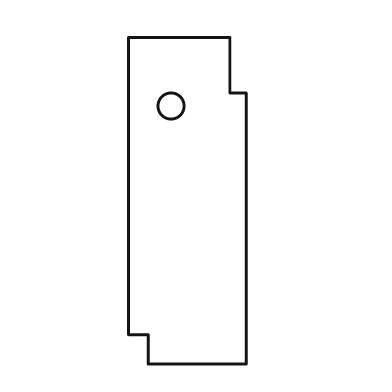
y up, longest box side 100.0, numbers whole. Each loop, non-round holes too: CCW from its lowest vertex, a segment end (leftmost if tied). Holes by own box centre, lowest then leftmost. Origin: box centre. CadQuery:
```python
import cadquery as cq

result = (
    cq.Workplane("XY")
    .moveTo(-12.0, -50.0)
    .lineTo(18.0, -50.0)
    .lineTo(18.0, 33.0)
    .lineTo(13.0, 33.0)
    .lineTo(13.0, 50.0)
    .lineTo(-18.0, 50.0)
    .lineTo(-18.0, -41.0)
    .lineTo(-12.0, -41.0)
    .close()
    .moveTo(-5.0, 29.0)
    .circle(4.0)
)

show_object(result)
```